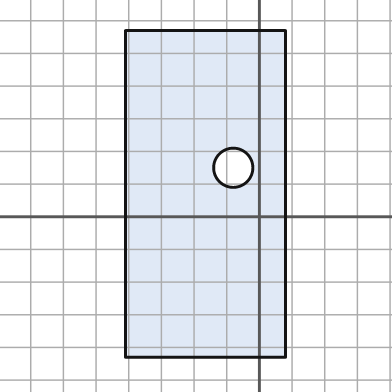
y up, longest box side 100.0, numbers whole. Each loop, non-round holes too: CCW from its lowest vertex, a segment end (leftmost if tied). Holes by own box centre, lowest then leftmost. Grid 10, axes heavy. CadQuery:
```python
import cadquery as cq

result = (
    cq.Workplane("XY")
    .moveTo(-41.0, -43.0)
    .lineTo(8.0, -43.0)
    .lineTo(8.0, 57.0)
    .lineTo(-41.0, 57.0)
    .close()
    .moveTo(-8.0, 15.0)
    .circle(6.0)
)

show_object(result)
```